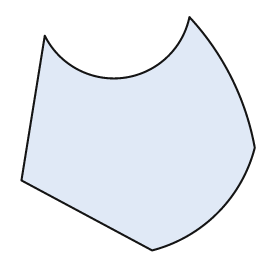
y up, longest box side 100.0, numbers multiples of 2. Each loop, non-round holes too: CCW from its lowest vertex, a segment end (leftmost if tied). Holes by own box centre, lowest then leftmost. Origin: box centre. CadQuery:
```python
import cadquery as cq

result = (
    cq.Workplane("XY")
    .moveTo(6.0, -50.0)
    .threePointArc((34.0, -34.0), (50.0, -6.0))
    .threePointArc((40.0, 24.0), (22.0, 50.0))
    .threePointArc((-6.0, 24.0), (-40.0, 42.0))
    .lineTo(-50.0, -20.0)
    .close()
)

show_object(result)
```